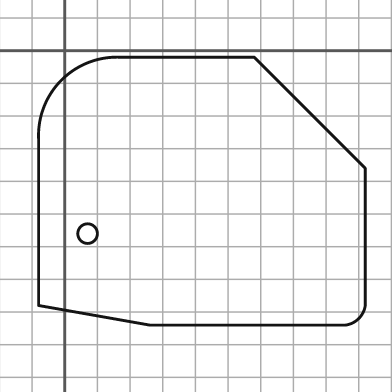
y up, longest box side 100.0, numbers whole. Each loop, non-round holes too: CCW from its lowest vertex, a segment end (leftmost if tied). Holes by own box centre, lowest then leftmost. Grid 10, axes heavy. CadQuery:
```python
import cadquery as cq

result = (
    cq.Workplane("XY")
    .moveTo(26.0, -84.0)
    .lineTo(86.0, -84.0)
    .threePointArc((90.0, -82.0), (92.0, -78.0))
    .lineTo(92.0, -36.0)
    .lineTo(58.0, -2.0)
    .lineTo(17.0, -2.0)
    .threePointArc((-1.0, -9.0), (-8.0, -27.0))
    .lineTo(-8.0, -78.0)
    .close()
    .moveTo(7.0, -56.0)
    .circle(3.0)
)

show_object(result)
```